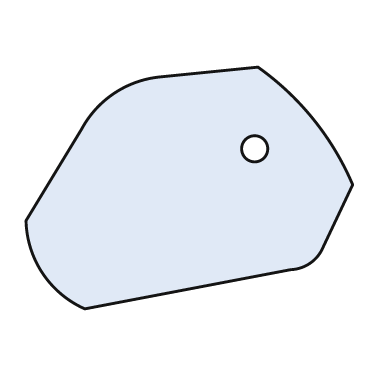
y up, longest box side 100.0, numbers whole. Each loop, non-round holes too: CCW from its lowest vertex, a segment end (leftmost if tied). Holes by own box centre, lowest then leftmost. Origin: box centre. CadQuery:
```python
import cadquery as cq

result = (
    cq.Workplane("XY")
    .moveTo(-32.0, -37.0)
    .lineTo(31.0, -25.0)
    .threePointArc((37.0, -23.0), (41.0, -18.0))
    .lineTo(50.0, 1.0)
    .threePointArc((38.0, 21.0), (21.0, 37.0))
    .lineTo(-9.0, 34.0)
    .threePointArc((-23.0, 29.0), (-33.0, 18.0))
    .lineTo(-50.0, -10.0)
    .threePointArc((-45.0, -26.0), (-32.0, -37.0))
    .close()
    .moveTo(20.0, 12.0)
    .circle(4.0)
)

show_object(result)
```